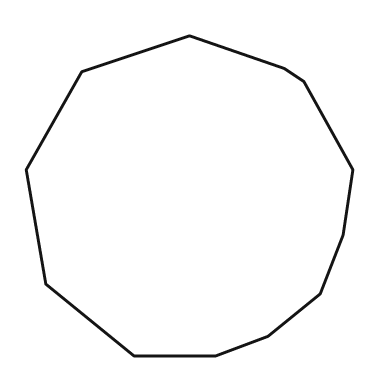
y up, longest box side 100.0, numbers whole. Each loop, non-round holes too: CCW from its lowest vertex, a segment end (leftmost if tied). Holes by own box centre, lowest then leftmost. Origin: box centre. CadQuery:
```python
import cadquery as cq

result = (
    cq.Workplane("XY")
    .moveTo(-17.0, -49.0)
    .lineTo(8.0, -49.0)
    .lineTo(24.0, -43.0)
    .lineTo(40.0, -30.0)
    .lineTo(47.0, -12.0)
    .lineTo(50.0, 8.0)
    .lineTo(35.0, 35.0)
    .lineTo(29.0, 39.0)
    .lineTo(0.0, 49.0)
    .lineTo(-33.0, 38.0)
    .lineTo(-50.0, 8.0)
    .lineTo(-44.0, -27.0)
    .close()
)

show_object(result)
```